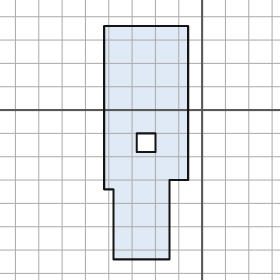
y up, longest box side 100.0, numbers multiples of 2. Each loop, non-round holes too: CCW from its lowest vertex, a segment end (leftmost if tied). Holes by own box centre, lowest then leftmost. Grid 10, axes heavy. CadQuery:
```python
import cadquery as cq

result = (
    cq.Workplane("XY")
    .moveTo(-38.0, -64.0)
    .lineTo(-14.0, -64.0)
    .lineTo(-14.0, -30.0)
    .lineTo(-6.0, -30.0)
    .lineTo(-6.0, 36.0)
    .lineTo(-42.0, 36.0)
    .lineTo(-42.0, -34.0)
    .lineTo(-38.0, -34.0)
    .close()
    .moveTo(-28.0, -18.0)
    .lineTo(-20.0, -18.0)
    .lineTo(-20.0, -10.0)
    .lineTo(-28.0, -10.0)
    .close()
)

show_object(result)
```